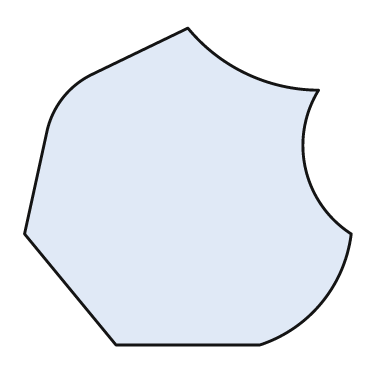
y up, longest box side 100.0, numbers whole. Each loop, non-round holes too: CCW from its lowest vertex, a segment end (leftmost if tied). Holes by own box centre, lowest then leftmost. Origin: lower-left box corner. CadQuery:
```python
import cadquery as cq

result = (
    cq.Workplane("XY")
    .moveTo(28.0, 0.0)
    .lineTo(72.0, 0.0)
    .threePointArc((91.0, 13.0), (100.0, 34.0))
    .threePointArc((86.0, 54.0), (90.0, 78.0))
    .threePointArc((68.0, 83.0), (50.0, 97.0))
    .lineTo(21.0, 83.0)
    .threePointArc((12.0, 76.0), (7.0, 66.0))
    .lineTo(0.0, 34.0)
    .close()
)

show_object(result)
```